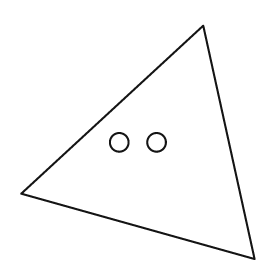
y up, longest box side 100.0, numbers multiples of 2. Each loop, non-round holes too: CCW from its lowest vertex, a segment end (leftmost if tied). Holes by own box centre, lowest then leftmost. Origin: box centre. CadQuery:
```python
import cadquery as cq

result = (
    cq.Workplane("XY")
    .moveTo(50.0, -50.0)
    .lineTo(28.0, 50.0)
    .lineTo(-50.0, -22.0)
    .close()
    .moveTo(-8.0, 0.0)
    .circle(4.0)
    .moveTo(8.0, 0.0)
    .circle(4.0)
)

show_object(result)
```